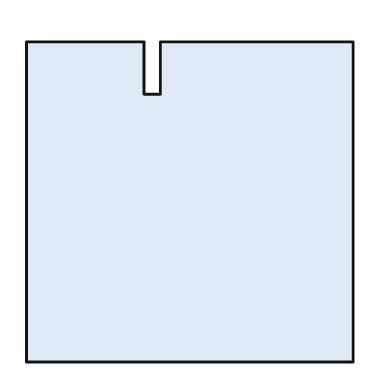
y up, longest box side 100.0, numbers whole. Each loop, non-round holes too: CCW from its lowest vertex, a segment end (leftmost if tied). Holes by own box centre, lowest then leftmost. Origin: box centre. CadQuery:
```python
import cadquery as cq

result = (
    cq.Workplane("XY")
    .moveTo(-50.0, -49.0)
    .lineTo(50.0, -49.0)
    .lineTo(50.0, 49.0)
    .lineTo(-9.0, 49.0)
    .lineTo(-9.0, 33.0)
    .lineTo(-14.0, 33.0)
    .lineTo(-14.0, 49.0)
    .lineTo(-50.0, 49.0)
    .close()
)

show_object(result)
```